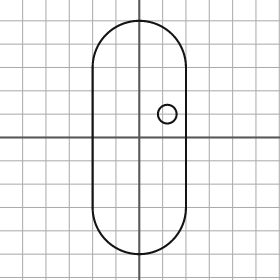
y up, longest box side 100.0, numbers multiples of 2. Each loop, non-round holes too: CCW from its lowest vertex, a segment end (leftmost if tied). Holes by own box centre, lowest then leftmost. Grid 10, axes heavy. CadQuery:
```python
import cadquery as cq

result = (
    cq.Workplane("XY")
    .moveTo(-20.0, -30.0)
    .threePointArc((0.0, -50.0), (20.0, -30.0))
    .lineTo(20.0, 30.0)
    .threePointArc((0.0, 50.0), (-20.0, 30.0))
    .close()
    .moveTo(12.0, 10.0)
    .circle(4.0)
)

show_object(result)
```